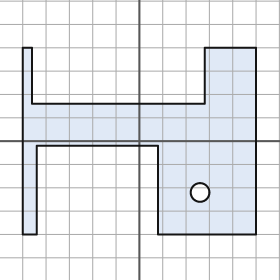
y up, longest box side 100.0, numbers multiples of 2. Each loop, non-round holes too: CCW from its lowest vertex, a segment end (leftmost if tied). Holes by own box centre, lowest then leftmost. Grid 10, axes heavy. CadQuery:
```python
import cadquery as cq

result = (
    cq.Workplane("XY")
    .moveTo(-50.0, -40.0)
    .lineTo(-44.0, -40.0)
    .lineTo(-44.0, -2.0)
    .lineTo(8.0, -2.0)
    .lineTo(8.0, -40.0)
    .lineTo(50.0, -40.0)
    .lineTo(50.0, 40.0)
    .lineTo(28.0, 40.0)
    .lineTo(28.0, 16.0)
    .lineTo(-46.0, 16.0)
    .lineTo(-46.0, 40.0)
    .lineTo(-50.0, 40.0)
    .close()
    .moveTo(26.0, -22.0)
    .circle(4.0)
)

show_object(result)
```